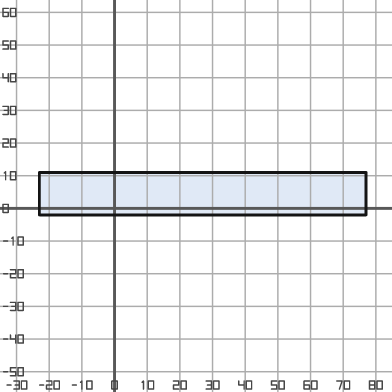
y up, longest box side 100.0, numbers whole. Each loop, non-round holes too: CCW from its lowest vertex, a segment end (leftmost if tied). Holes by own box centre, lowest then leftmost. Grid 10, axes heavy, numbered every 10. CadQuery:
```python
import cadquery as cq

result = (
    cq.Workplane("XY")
    .moveTo(-23.0, -2.0)
    .lineTo(77.0, -2.0)
    .lineTo(77.0, 11.0)
    .lineTo(-23.0, 11.0)
    .close()
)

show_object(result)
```